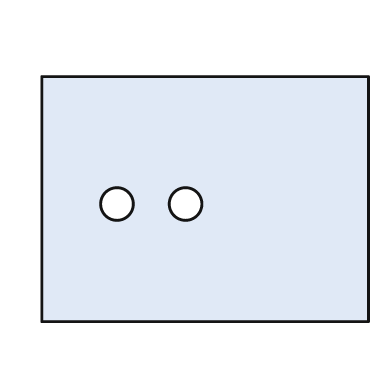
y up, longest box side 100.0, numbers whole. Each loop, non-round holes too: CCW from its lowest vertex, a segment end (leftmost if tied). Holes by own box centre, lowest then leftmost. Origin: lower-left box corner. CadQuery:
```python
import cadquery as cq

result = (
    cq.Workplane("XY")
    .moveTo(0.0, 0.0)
    .lineTo(100.0, 0.0)
    .lineTo(100.0, 75.0)
    .lineTo(0.0, 75.0)
    .close()
    .moveTo(23.0, 36.0)
    .circle(5.0)
    .moveTo(44.0, 36.0)
    .circle(5.0)
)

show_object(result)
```